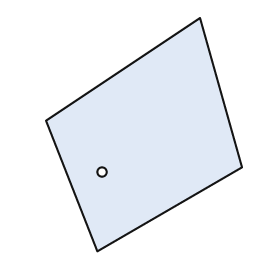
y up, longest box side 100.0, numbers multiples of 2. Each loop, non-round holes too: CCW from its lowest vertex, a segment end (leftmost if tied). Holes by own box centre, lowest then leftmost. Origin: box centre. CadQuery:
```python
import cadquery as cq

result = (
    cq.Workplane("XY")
    .moveTo(-20.0, -50.0)
    .lineTo(42.0, -14.0)
    .lineTo(24.0, 50.0)
    .lineTo(-42.0, 6.0)
    .close()
    .moveTo(-18.0, -16.0)
    .circle(2.0)
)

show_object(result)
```